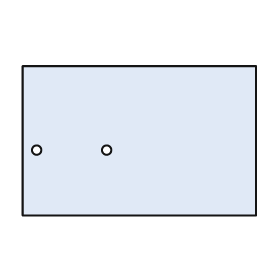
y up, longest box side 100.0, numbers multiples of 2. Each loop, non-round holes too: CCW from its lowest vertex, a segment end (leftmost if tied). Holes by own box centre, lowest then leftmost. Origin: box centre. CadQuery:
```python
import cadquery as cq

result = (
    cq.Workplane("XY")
    .moveTo(-50.0, -32.0)
    .lineTo(50.0, -32.0)
    .lineTo(50.0, 32.0)
    .lineTo(-50.0, 32.0)
    .close()
    .moveTo(-44.0, -4.0)
    .circle(2.0)
    .moveTo(-14.0, -4.0)
    .circle(2.0)
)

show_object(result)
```